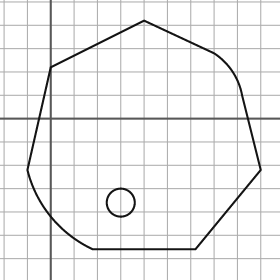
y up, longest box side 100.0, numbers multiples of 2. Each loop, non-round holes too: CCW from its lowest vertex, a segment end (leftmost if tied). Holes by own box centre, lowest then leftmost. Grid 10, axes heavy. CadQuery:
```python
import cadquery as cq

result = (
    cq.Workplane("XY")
    .moveTo(18.0, -56.0)
    .lineTo(62.0, -56.0)
    .lineTo(90.0, -22.0)
    .lineTo(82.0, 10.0)
    .threePointArc((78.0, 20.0), (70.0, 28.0))
    .lineTo(40.0, 42.0)
    .lineTo(0.0, 22.0)
    .lineTo(-10.0, -22.0)
    .threePointArc((0.0, -42.0), (18.0, -56.0))
    .close()
    .moveTo(30.0, -36.0)
    .circle(6.0)
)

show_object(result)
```